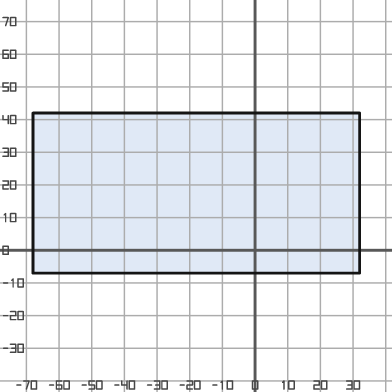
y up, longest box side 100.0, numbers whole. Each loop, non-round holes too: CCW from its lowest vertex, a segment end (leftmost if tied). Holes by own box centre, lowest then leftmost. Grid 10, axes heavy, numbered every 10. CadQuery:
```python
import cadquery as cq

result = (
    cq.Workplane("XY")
    .moveTo(-68.0, -7.0)
    .lineTo(32.0, -7.0)
    .lineTo(32.0, 42.0)
    .lineTo(-68.0, 42.0)
    .close()
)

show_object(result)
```